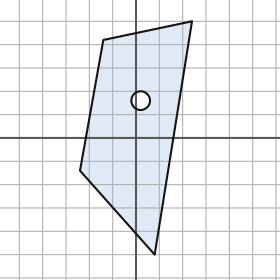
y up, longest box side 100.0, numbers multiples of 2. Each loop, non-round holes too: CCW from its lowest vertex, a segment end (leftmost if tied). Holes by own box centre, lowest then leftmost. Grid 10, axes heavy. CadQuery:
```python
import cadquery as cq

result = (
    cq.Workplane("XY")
    .moveTo(8.0, -50.0)
    .lineTo(24.0, 50.0)
    .lineTo(-14.0, 42.0)
    .lineTo(-24.0, -14.0)
    .close()
    .moveTo(2.0, 16.0)
    .circle(4.0)
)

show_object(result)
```